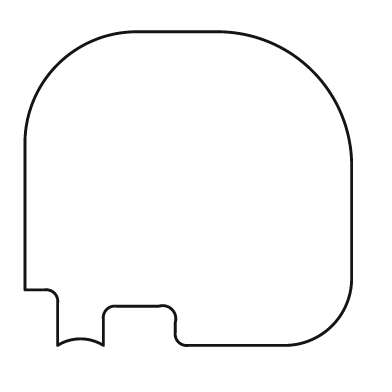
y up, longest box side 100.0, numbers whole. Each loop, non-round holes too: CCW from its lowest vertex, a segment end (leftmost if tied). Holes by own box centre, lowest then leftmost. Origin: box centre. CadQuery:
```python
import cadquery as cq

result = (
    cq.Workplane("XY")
    .moveTo(-40.0, -48.0)
    .threePointArc((-33.0, -46.0), (-26.0, -48.0))
    .lineTo(-26.0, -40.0)
    .threePointArc((-25.0, -37.0), (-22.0, -36.0))
    .lineTo(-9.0, -36.0)
    .threePointArc((-5.0, -37.0), (-4.0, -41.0))
    .lineTo(-4.0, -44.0)
    .threePointArc((-3.0, -47.0), (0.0, -48.0))
    .lineTo(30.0, -48.0)
    .threePointArc((44.0, -42.0), (50.0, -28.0))
    .lineTo(50.0, 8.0)
    .threePointArc((38.0, 36.0), (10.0, 48.0))
    .lineTo(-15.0, 48.0)
    .threePointArc((-40.0, 38.0), (-50.0, 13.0))
    .lineTo(-50.0, -31.0)
    .lineTo(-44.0, -31.0)
    .threePointArc((-41.0, -32.0), (-40.0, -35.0))
    .close()
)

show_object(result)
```